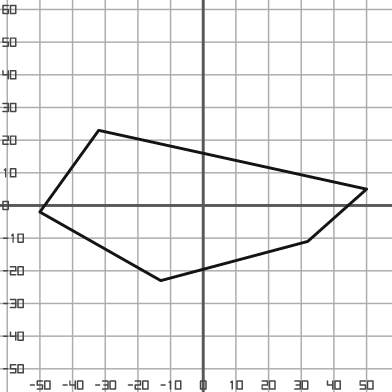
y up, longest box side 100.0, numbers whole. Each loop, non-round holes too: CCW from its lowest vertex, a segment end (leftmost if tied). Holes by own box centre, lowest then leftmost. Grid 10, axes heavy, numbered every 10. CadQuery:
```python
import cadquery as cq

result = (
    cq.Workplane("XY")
    .moveTo(-13.0, -23.0)
    .lineTo(32.0, -11.0)
    .lineTo(50.0, 5.0)
    .lineTo(-32.0, 23.0)
    .lineTo(-50.0, -2.0)
    .close()
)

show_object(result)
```